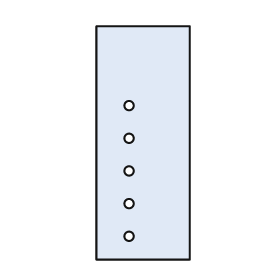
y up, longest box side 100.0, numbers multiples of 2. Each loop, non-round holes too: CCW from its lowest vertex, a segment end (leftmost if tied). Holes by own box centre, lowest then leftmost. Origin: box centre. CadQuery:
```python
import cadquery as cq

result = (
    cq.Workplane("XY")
    .moveTo(-20.0, -50.0)
    .lineTo(20.0, -50.0)
    .lineTo(20.0, 50.0)
    .lineTo(-20.0, 50.0)
    .close()
    .moveTo(-6.0, -40.0)
    .circle(2.0)
    .moveTo(-6.0, -26.0)
    .circle(2.0)
    .moveTo(-6.0, -12.0)
    .circle(2.0)
    .moveTo(-6.0, 2.0)
    .circle(2.0)
    .moveTo(-6.0, 16.0)
    .circle(2.0)
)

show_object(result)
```